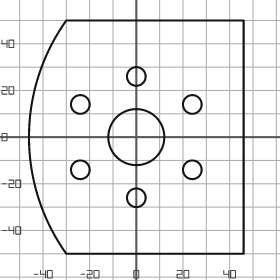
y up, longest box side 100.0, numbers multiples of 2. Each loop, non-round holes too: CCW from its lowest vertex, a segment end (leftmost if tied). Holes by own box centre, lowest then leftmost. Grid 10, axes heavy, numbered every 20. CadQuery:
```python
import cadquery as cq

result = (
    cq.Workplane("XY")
    .moveTo(-30.0, -50.0)
    .lineTo(46.0, -50.0)
    .lineTo(46.0, 50.0)
    .lineTo(-30.0, 50.0)
    .threePointArc((-46.0, 0.0), (-30.0, -50.0))
    .close()
    .moveTo(0.0, -26.0)
    .circle(4.0)
    .moveTo(-24.0, -14.0)
    .circle(4.0)
    .moveTo(24.0, -14.0)
    .circle(4.0)
    .moveTo(0.0, 0.0)
    .circle(12.0)
    .moveTo(-24.0, 14.0)
    .circle(4.0)
    .moveTo(24.0, 14.0)
    .circle(4.0)
    .moveTo(0.0, 26.0)
    .circle(4.0)
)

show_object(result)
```